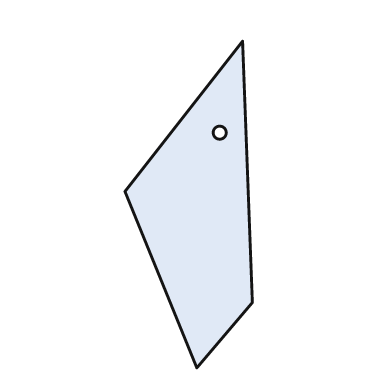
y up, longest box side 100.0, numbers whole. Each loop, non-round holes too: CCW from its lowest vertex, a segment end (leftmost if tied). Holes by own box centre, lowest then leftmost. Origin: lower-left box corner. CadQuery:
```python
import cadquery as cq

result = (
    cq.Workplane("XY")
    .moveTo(22.0, 0.0)
    .lineTo(39.0, 20.0)
    .lineTo(36.0, 100.0)
    .lineTo(0.0, 54.0)
    .close()
    .moveTo(29.0, 72.0)
    .circle(2.0)
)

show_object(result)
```